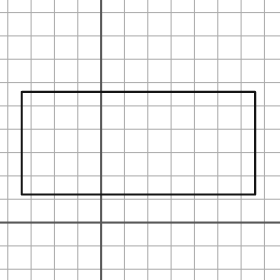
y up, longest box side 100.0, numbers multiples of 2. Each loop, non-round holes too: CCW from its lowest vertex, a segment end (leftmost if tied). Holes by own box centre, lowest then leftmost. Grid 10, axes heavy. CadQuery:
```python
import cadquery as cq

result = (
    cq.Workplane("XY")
    .moveTo(-34.0, 12.0)
    .lineTo(66.0, 12.0)
    .lineTo(66.0, 56.0)
    .lineTo(-34.0, 56.0)
    .close()
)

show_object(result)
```